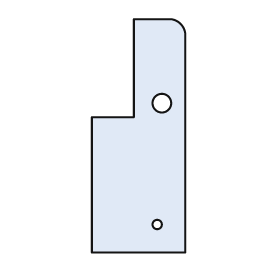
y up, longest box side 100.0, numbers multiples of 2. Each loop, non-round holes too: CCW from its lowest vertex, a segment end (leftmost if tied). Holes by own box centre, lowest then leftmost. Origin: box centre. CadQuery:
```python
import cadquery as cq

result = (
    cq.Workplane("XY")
    .moveTo(-20.0, -50.0)
    .lineTo(20.0, -50.0)
    .lineTo(20.0, 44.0)
    .threePointArc((18.0, 48.0), (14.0, 50.0))
    .lineTo(-2.0, 50.0)
    .lineTo(-2.0, 8.0)
    .lineTo(-20.0, 8.0)
    .close()
    .moveTo(8.0, -38.0)
    .circle(2.0)
    .moveTo(10.0, 14.0)
    .circle(4.0)
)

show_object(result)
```